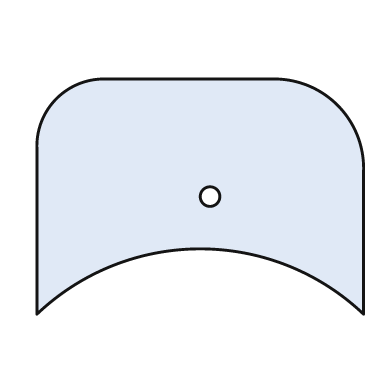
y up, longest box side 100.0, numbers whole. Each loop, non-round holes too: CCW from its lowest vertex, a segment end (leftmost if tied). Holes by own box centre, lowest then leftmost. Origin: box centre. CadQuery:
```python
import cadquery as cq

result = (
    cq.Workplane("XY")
    .moveTo(-50.0, -36.0)
    .threePointArc((0.0, -16.0), (50.0, -36.0))
    .lineTo(50.0, 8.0)
    .threePointArc((42.0, 28.0), (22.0, 36.0))
    .lineTo(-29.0, 36.0)
    .threePointArc((-44.0, 30.0), (-50.0, 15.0))
    .close()
    .moveTo(3.0, 0.0)
    .circle(3.0)
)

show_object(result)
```